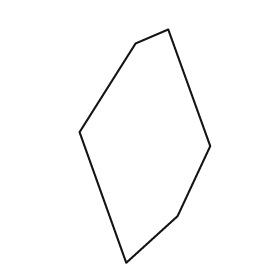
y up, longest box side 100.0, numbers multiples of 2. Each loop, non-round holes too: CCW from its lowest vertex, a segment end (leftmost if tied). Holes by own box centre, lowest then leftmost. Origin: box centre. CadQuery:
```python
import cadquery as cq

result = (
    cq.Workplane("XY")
    .moveTo(-8.0, -50.0)
    .lineTo(14.0, -30.0)
    .lineTo(28.0, 0.0)
    .lineTo(10.0, 50.0)
    .lineTo(-4.0, 44.0)
    .lineTo(-28.0, 6.0)
    .close()
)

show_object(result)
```